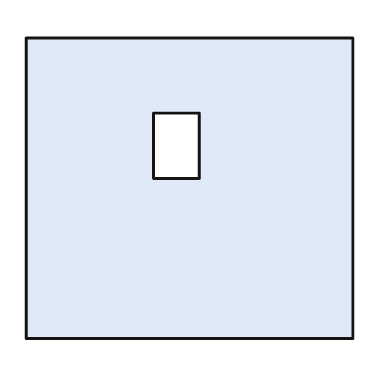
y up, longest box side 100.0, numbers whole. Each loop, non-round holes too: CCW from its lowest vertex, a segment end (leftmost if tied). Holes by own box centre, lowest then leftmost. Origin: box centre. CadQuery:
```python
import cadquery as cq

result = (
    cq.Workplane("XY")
    .moveTo(-50.0, -46.0)
    .lineTo(50.0, -46.0)
    .lineTo(50.0, 46.0)
    .lineTo(-50.0, 46.0)
    .close()
    .moveTo(-11.0, 3.0)
    .lineTo(3.0, 3.0)
    .lineTo(3.0, 23.0)
    .lineTo(-11.0, 23.0)
    .close()
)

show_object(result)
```